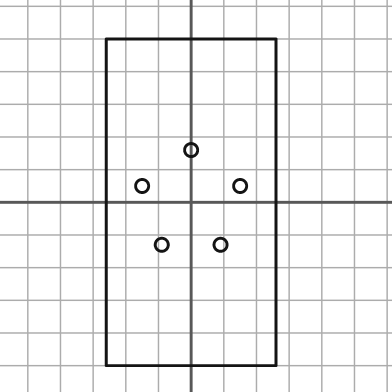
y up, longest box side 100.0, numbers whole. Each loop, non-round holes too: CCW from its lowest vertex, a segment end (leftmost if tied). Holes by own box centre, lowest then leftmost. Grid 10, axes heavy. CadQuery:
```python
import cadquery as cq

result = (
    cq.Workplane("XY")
    .moveTo(-26.0, -50.0)
    .lineTo(26.0, -50.0)
    .lineTo(26.0, 50.0)
    .lineTo(-26.0, 50.0)
    .close()
    .moveTo(-9.0, -13.0)
    .circle(2.0)
    .moveTo(9.0, -13.0)
    .circle(2.0)
    .moveTo(-15.0, 5.0)
    .circle(2.0)
    .moveTo(15.0, 5.0)
    .circle(2.0)
    .moveTo(0.0, 16.0)
    .circle(2.0)
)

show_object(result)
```